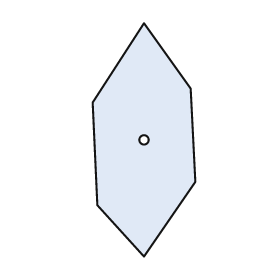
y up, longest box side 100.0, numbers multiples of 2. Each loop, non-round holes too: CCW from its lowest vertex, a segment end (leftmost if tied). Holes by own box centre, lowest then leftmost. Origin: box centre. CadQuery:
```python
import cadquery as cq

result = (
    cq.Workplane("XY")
    .moveTo(0.0, -50.0)
    .lineTo(22.0, -18.0)
    .lineTo(20.0, 22.0)
    .lineTo(0.0, 50.0)
    .lineTo(-22.0, 16.0)
    .lineTo(-20.0, -28.0)
    .close()
    .moveTo(0.0, 0.0)
    .circle(2.0)
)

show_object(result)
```